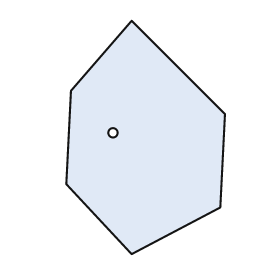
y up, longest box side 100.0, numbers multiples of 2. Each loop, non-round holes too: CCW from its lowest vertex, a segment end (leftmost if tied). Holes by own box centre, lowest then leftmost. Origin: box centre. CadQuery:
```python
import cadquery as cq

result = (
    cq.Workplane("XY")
    .moveTo(-6.0, -50.0)
    .lineTo(32.0, -30.0)
    .lineTo(34.0, 10.0)
    .lineTo(-6.0, 50.0)
    .lineTo(-32.0, 20.0)
    .lineTo(-34.0, -20.0)
    .close()
    .moveTo(-14.0, 2.0)
    .circle(2.0)
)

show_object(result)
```